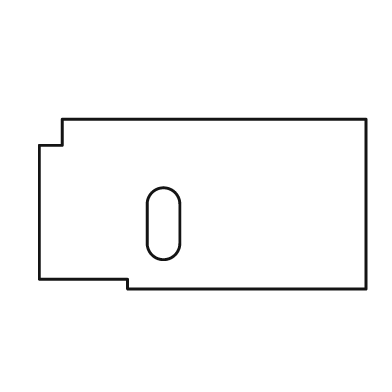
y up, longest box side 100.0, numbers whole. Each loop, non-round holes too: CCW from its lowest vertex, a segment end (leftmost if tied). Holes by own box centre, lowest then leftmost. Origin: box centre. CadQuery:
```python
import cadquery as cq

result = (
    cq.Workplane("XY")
    .moveTo(-23.0, -26.0)
    .lineTo(50.0, -26.0)
    .lineTo(50.0, 26.0)
    .lineTo(-43.0, 26.0)
    .lineTo(-43.0, 18.0)
    .lineTo(-50.0, 18.0)
    .lineTo(-50.0, -23.0)
    .lineTo(-23.0, -23.0)
    .close()
    .moveTo(-17.0, -12.0)
    .threePointArc((-12.0, -17.0), (-7.0, -12.0))
    .lineTo(-7.0, 0.0)
    .threePointArc((-12.0, 5.0), (-17.0, 0.0))
    .close()
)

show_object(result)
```